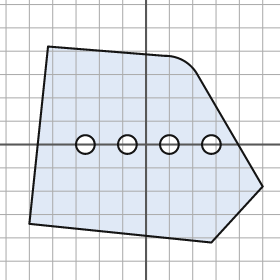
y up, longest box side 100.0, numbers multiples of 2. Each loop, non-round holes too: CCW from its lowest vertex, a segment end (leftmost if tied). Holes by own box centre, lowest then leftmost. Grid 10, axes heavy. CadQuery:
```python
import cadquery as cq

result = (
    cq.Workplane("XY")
    .moveTo(28.0, -42.0)
    .lineTo(50.0, -18.0)
    .lineTo(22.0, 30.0)
    .threePointArc((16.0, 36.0), (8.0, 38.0))
    .lineTo(-42.0, 42.0)
    .lineTo(-50.0, -34.0)
    .close()
    .moveTo(-26.0, 0.0)
    .circle(4.0)
    .moveTo(-8.0, 0.0)
    .circle(4.0)
    .moveTo(10.0, 0.0)
    .circle(4.0)
    .moveTo(28.0, 0.0)
    .circle(4.0)
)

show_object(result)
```